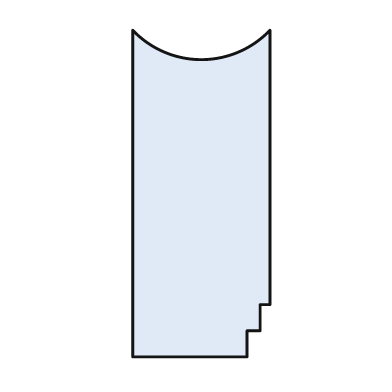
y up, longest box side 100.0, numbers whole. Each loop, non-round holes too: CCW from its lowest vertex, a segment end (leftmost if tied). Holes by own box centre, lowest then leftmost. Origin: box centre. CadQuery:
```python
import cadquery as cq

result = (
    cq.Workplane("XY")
    .moveTo(-21.0, -50.0)
    .lineTo(14.0, -50.0)
    .lineTo(14.0, -42.0)
    .lineTo(18.0, -42.0)
    .lineTo(18.0, -34.0)
    .lineTo(21.0, -34.0)
    .lineTo(21.0, 50.0)
    .threePointArc((0.0, 41.0), (-21.0, 50.0))
    .close()
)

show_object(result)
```